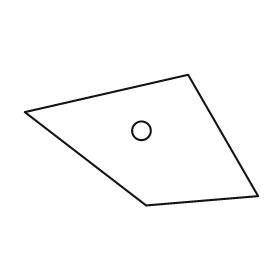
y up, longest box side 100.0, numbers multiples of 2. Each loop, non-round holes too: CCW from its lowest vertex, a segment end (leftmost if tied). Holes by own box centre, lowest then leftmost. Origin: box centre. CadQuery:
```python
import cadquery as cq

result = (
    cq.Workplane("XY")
    .moveTo(2.0, -28.0)
    .lineTo(50.0, -24.0)
    .lineTo(20.0, 28.0)
    .lineTo(-50.0, 12.0)
    .close()
    .moveTo(0.0, 4.0)
    .circle(4.0)
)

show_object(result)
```